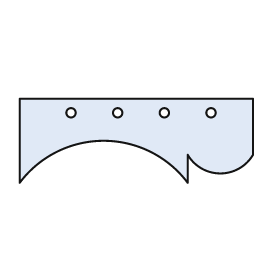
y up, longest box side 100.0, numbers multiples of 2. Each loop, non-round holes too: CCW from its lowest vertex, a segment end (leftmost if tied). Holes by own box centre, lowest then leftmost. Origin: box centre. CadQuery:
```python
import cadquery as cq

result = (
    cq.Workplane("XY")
    .moveTo(-50.0, -18.0)
    .threePointArc((-14.0, 0.0), (22.0, -18.0))
    .lineTo(22.0, -6.0)
    .threePointArc((36.0, -14.0), (50.0, -6.0))
    .lineTo(50.0, 18.0)
    .lineTo(-50.0, 18.0)
    .close()
    .moveTo(-28.0, 12.0)
    .circle(2.0)
    .moveTo(-8.0, 12.0)
    .circle(2.0)
    .moveTo(12.0, 12.0)
    .circle(2.0)
    .moveTo(32.0, 12.0)
    .circle(2.0)
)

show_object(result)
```